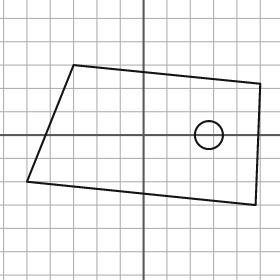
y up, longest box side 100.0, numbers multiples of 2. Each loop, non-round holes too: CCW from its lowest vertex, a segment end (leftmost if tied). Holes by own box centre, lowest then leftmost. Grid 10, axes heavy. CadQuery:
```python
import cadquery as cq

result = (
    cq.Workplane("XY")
    .moveTo(48.0, -30.0)
    .lineTo(50.0, 22.0)
    .lineTo(-30.0, 30.0)
    .lineTo(-50.0, -20.0)
    .close()
    .moveTo(28.0, 0.0)
    .circle(6.0)
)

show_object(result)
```